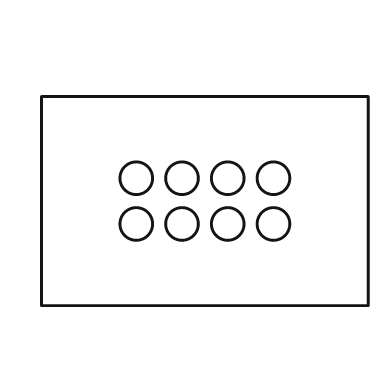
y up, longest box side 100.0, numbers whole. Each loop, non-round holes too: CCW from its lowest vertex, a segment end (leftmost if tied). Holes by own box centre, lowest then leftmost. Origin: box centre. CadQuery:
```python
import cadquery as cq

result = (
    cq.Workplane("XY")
    .moveTo(-50.0, -32.0)
    .lineTo(50.0, -32.0)
    .lineTo(50.0, 32.0)
    .lineTo(-50.0, 32.0)
    .close()
    .moveTo(-21.0, -7.0)
    .circle(5.0)
    .moveTo(-7.0, -7.0)
    .circle(5.0)
    .moveTo(7.0, -7.0)
    .circle(5.0)
    .moveTo(21.0, -7.0)
    .circle(5.0)
    .moveTo(-21.0, 7.0)
    .circle(5.0)
    .moveTo(-7.0, 7.0)
    .circle(5.0)
    .moveTo(7.0, 7.0)
    .circle(5.0)
    .moveTo(21.0, 7.0)
    .circle(5.0)
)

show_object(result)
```